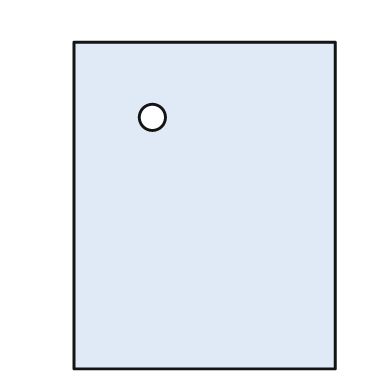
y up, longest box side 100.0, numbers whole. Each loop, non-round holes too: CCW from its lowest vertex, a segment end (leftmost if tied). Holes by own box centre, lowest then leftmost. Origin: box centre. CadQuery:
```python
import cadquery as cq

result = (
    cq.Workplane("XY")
    .moveTo(-40.0, -50.0)
    .lineTo(40.0, -50.0)
    .lineTo(40.0, 50.0)
    .lineTo(-40.0, 50.0)
    .close()
    .moveTo(-16.0, 27.0)
    .circle(4.0)
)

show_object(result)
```